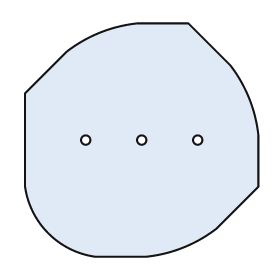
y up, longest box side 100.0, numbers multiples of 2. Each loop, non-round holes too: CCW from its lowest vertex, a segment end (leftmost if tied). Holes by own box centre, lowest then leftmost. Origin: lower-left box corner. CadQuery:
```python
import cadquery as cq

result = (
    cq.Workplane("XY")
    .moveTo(30.0, 0.0)
    .lineTo(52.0, 0.0)
    .threePointArc((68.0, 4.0), (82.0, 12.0))
    .lineTo(100.0, 30.0)
    .lineTo(100.0, 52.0)
    .threePointArc((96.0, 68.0), (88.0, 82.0))
    .lineTo(70.0, 100.0)
    .lineTo(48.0, 100.0)
    .threePointArc((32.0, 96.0), (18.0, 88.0))
    .lineTo(0.0, 70.0)
    .lineTo(0.0, 30.0)
    .threePointArc((10.0, 10.0), (30.0, 0.0))
    .close()
    .moveTo(26.0, 50.0)
    .circle(2.0)
    .moveTo(50.0, 50.0)
    .circle(2.0)
    .moveTo(74.0, 50.0)
    .circle(2.0)
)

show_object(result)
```